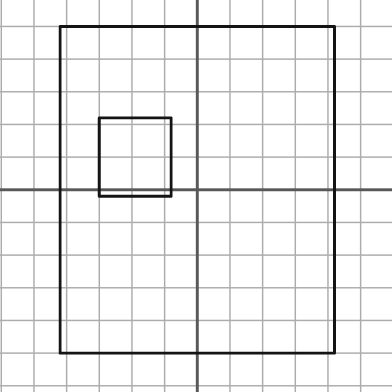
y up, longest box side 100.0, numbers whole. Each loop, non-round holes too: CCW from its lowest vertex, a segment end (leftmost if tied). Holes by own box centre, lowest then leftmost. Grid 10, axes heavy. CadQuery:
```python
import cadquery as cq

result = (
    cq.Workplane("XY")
    .moveTo(-42.0, -50.0)
    .lineTo(42.0, -50.0)
    .lineTo(42.0, 50.0)
    .lineTo(-42.0, 50.0)
    .close()
    .moveTo(-30.0, -2.0)
    .lineTo(-8.0, -2.0)
    .lineTo(-8.0, 22.0)
    .lineTo(-30.0, 22.0)
    .close()
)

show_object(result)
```